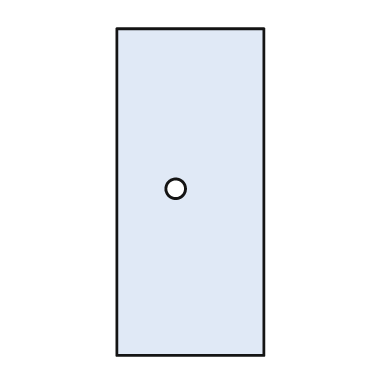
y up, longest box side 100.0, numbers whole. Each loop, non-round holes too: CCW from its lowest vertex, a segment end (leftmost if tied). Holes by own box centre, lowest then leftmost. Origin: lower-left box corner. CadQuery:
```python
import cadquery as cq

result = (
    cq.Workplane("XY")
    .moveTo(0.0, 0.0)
    .lineTo(45.0, 0.0)
    .lineTo(45.0, 100.0)
    .lineTo(0.0, 100.0)
    .close()
    .moveTo(18.0, 51.0)
    .circle(3.0)
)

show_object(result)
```